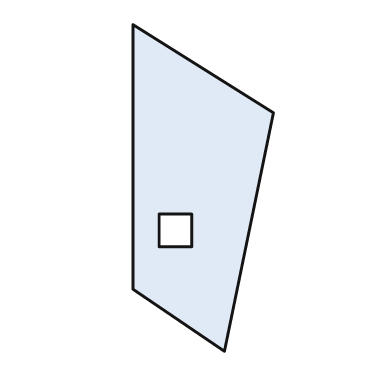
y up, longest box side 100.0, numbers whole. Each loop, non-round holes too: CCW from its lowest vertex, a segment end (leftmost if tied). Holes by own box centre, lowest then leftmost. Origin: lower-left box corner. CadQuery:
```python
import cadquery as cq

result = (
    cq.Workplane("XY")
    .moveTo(28.0, 0.0)
    .lineTo(43.0, 73.0)
    .lineTo(0.0, 100.0)
    .lineTo(0.0, 19.0)
    .close()
    .moveTo(8.0, 32.0)
    .lineTo(18.0, 32.0)
    .lineTo(18.0, 42.0)
    .lineTo(8.0, 42.0)
    .close()
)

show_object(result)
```